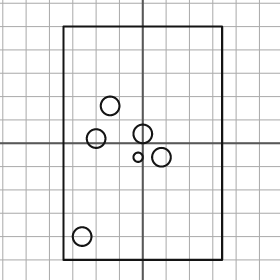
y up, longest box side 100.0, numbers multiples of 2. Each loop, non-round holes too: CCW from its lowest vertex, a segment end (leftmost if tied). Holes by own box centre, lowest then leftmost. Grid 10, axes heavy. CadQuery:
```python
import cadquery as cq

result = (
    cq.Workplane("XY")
    .moveTo(-34.0, -50.0)
    .lineTo(34.0, -50.0)
    .lineTo(34.0, 50.0)
    .lineTo(-34.0, 50.0)
    .close()
    .moveTo(-26.0, -40.0)
    .circle(4.0)
    .moveTo(-2.0, -6.0)
    .circle(2.0)
    .moveTo(8.0, -6.0)
    .circle(4.0)
    .moveTo(-20.0, 2.0)
    .circle(4.0)
    .moveTo(0.0, 4.0)
    .circle(4.0)
    .moveTo(-14.0, 16.0)
    .circle(4.0)
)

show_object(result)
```